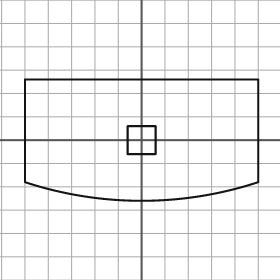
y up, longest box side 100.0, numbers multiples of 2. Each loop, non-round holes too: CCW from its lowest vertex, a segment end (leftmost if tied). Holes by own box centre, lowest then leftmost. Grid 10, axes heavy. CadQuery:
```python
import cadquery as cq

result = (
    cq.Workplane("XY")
    .moveTo(-50.0, -18.0)
    .threePointArc((0.0, -26.0), (50.0, -18.0))
    .lineTo(50.0, 26.0)
    .lineTo(-50.0, 26.0)
    .close()
    .moveTo(-6.0, -6.0)
    .lineTo(6.0, -6.0)
    .lineTo(6.0, 6.0)
    .lineTo(-6.0, 6.0)
    .close()
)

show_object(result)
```